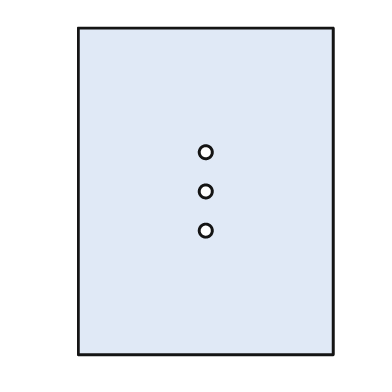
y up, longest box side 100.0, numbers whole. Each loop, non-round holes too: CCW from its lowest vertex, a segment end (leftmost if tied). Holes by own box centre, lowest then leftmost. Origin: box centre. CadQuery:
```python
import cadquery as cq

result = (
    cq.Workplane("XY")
    .moveTo(-39.0, -50.0)
    .lineTo(39.0, -50.0)
    .lineTo(39.0, 50.0)
    .lineTo(-39.0, 50.0)
    .close()
    .moveTo(0.0, -12.0)
    .circle(2.0)
    .moveTo(0.0, 0.0)
    .circle(2.0)
    .moveTo(0.0, 12.0)
    .circle(2.0)
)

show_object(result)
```